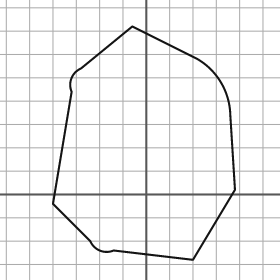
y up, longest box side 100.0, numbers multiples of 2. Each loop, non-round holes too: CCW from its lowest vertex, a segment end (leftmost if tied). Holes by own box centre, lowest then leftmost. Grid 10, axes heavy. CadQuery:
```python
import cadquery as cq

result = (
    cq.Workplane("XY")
    .moveTo(20.0, -28.0)
    .lineTo(38.0, 2.0)
    .lineTo(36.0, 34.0)
    .threePointArc((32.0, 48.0), (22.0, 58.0))
    .lineTo(-6.0, 72.0)
    .lineTo(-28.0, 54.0)
    .threePointArc((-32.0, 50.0), (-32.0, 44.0))
    .lineTo(-40.0, -4.0)
    .lineTo(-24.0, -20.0)
    .threePointArc((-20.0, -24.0), (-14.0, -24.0))
    .close()
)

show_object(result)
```